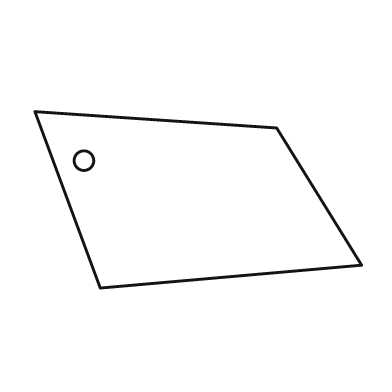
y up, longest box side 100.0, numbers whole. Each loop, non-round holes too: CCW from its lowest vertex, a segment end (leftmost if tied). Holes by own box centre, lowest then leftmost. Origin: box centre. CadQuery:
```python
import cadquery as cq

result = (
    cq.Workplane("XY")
    .moveTo(-30.0, -27.0)
    .lineTo(50.0, -20.0)
    .lineTo(24.0, 22.0)
    .lineTo(-50.0, 27.0)
    .close()
    .moveTo(-35.0, 12.0)
    .circle(3.0)
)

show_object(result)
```